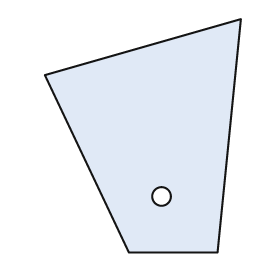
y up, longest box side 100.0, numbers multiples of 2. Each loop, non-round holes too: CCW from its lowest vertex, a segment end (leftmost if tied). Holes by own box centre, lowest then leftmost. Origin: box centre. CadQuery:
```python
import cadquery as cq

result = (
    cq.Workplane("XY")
    .moveTo(-6.0, -50.0)
    .lineTo(32.0, -50.0)
    .lineTo(42.0, 50.0)
    .lineTo(-42.0, 26.0)
    .close()
    .moveTo(8.0, -26.0)
    .circle(4.0)
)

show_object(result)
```